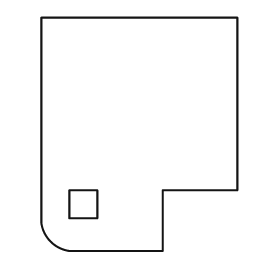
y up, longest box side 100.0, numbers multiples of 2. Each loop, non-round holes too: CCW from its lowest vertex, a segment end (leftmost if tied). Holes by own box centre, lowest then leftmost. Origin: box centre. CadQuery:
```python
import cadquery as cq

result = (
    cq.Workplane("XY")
    .moveTo(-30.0, -50.0)
    .lineTo(10.0, -50.0)
    .lineTo(10.0, -24.0)
    .lineTo(42.0, -24.0)
    .lineTo(42.0, 50.0)
    .lineTo(-42.0, 50.0)
    .lineTo(-42.0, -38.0)
    .threePointArc((-38.0, -46.0), (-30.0, -50.0))
    .close()
    .moveTo(-30.0, -36.0)
    .lineTo(-18.0, -36.0)
    .lineTo(-18.0, -24.0)
    .lineTo(-30.0, -24.0)
    .close()
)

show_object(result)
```